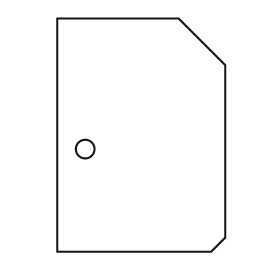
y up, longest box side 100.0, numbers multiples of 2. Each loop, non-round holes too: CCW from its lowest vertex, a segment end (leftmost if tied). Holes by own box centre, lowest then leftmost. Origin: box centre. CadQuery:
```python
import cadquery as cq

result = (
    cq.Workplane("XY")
    .moveTo(-36.0, -50.0)
    .lineTo(30.0, -50.0)
    .lineTo(36.0, -44.0)
    .lineTo(36.0, 30.0)
    .lineTo(16.0, 50.0)
    .lineTo(-36.0, 50.0)
    .close()
    .moveTo(-24.0, -6.0)
    .circle(4.0)
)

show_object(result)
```